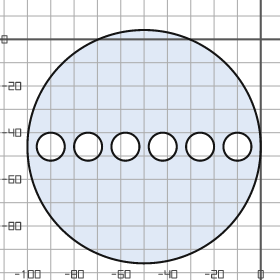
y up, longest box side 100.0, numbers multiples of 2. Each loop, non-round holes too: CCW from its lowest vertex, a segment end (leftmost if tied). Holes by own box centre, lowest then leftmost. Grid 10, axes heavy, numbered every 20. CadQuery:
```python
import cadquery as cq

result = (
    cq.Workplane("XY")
    .moveTo(-50.0, -46.0)
    .circle(50.0)
    .moveTo(-90.0, -46.0)
    .circle(6.0)
    .moveTo(-74.0, -46.0)
    .circle(6.0)
    .moveTo(-58.0, -46.0)
    .circle(6.0)
    .moveTo(-42.0, -46.0)
    .circle(6.0)
    .moveTo(-26.0, -46.0)
    .circle(6.0)
    .moveTo(-10.0, -46.0)
    .circle(6.0)
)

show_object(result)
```